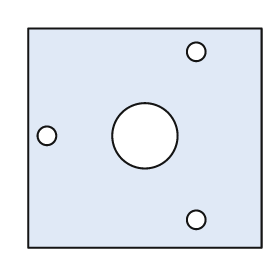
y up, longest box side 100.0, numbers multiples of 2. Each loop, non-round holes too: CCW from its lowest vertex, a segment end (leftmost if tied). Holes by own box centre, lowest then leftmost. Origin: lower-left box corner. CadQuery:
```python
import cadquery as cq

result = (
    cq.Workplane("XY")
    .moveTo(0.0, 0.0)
    .lineTo(100.0, 0.0)
    .lineTo(100.0, 94.0)
    .lineTo(0.0, 94.0)
    .close()
    .moveTo(72.0, 12.0)
    .circle(4.0)
    .moveTo(8.0, 48.0)
    .circle(4.0)
    .moveTo(50.0, 48.0)
    .circle(14.0)
    .moveTo(72.0, 84.0)
    .circle(4.0)
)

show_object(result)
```